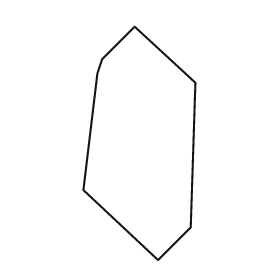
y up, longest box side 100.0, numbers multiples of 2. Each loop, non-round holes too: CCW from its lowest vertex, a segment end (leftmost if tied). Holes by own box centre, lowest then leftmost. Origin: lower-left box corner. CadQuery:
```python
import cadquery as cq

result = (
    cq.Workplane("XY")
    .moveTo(32.0, 0.0)
    .lineTo(46.0, 14.0)
    .lineTo(48.0, 76.0)
    .lineTo(22.0, 100.0)
    .lineTo(8.0, 86.0)
    .lineTo(6.0, 80.0)
    .lineTo(0.0, 30.0)
    .close()
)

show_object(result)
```